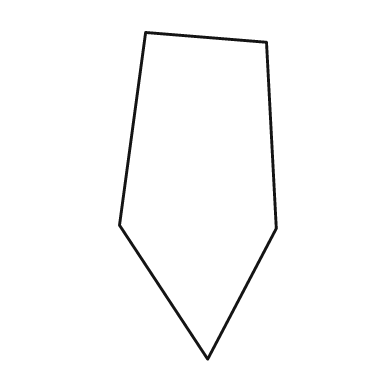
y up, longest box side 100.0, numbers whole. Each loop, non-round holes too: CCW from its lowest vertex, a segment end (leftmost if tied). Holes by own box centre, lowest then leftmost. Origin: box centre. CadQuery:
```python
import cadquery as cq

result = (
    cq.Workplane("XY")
    .moveTo(3.0, -50.0)
    .lineTo(24.0, -10.0)
    .lineTo(21.0, 47.0)
    .lineTo(-16.0, 50.0)
    .lineTo(-24.0, -9.0)
    .close()
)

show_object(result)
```